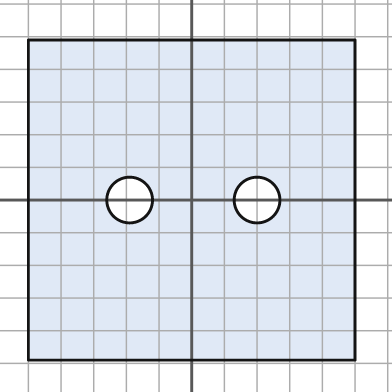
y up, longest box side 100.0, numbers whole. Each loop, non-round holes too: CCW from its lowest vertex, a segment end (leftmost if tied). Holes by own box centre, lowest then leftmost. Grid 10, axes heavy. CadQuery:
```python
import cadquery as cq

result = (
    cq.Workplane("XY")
    .moveTo(-50.0, -49.0)
    .lineTo(50.0, -49.0)
    .lineTo(50.0, 49.0)
    .lineTo(-50.0, 49.0)
    .close()
    .moveTo(-19.0, 0.0)
    .circle(7.0)
    .moveTo(20.0, 0.0)
    .circle(7.0)
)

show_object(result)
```